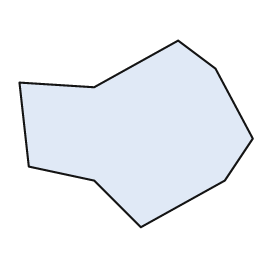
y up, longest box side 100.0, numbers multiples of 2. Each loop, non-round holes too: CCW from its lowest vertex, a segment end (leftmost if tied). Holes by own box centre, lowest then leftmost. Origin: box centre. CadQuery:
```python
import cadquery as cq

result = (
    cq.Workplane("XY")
    .moveTo(2.0, -40.0)
    .lineTo(38.0, -20.0)
    .lineTo(50.0, -2.0)
    .lineTo(34.0, 28.0)
    .lineTo(18.0, 40.0)
    .lineTo(-18.0, 20.0)
    .lineTo(-50.0, 22.0)
    .lineTo(-46.0, -14.0)
    .lineTo(-18.0, -20.0)
    .close()
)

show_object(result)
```